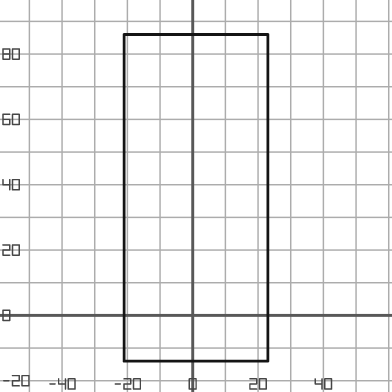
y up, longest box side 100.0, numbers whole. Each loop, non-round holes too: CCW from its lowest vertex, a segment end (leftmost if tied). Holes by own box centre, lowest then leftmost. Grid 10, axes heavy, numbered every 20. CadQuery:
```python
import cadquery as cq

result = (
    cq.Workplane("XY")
    .moveTo(-21.0, -14.0)
    .lineTo(23.0, -14.0)
    .lineTo(23.0, 86.0)
    .lineTo(-21.0, 86.0)
    .close()
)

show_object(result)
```